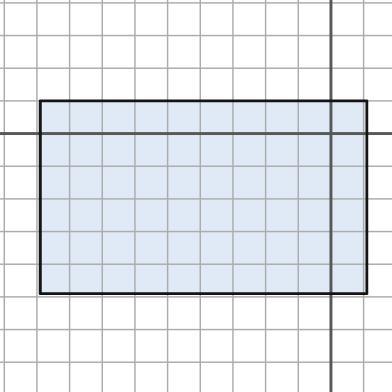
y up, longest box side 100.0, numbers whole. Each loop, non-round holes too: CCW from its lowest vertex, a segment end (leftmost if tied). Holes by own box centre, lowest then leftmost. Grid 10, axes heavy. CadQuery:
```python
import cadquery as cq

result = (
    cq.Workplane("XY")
    .moveTo(-89.0, -49.0)
    .lineTo(11.0, -49.0)
    .lineTo(11.0, 10.0)
    .lineTo(-89.0, 10.0)
    .close()
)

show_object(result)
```